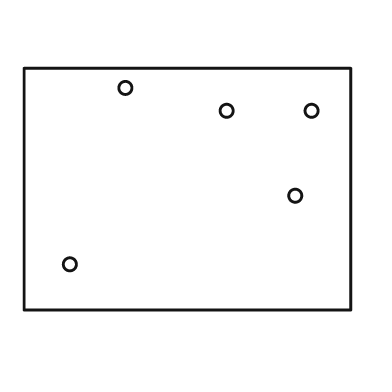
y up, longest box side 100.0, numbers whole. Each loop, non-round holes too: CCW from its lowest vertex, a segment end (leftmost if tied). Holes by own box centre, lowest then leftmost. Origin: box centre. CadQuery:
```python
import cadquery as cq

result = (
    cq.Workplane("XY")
    .moveTo(-50.0, -37.0)
    .lineTo(50.0, -37.0)
    .lineTo(50.0, 37.0)
    .lineTo(-50.0, 37.0)
    .close()
    .moveTo(-36.0, -23.0)
    .circle(2.0)
    .moveTo(33.0, -2.0)
    .circle(2.0)
    .moveTo(12.0, 24.0)
    .circle(2.0)
    .moveTo(38.0, 24.0)
    .circle(2.0)
    .moveTo(-19.0, 31.0)
    .circle(2.0)
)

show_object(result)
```